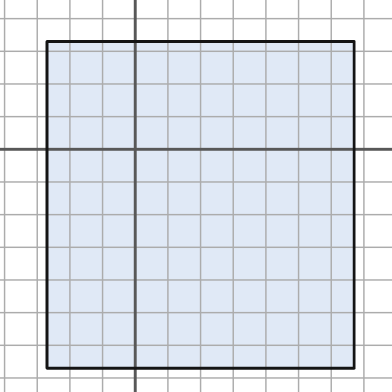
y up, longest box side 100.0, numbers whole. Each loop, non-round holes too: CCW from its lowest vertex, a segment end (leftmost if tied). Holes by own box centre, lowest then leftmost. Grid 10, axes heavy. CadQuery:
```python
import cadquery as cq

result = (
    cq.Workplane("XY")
    .moveTo(-27.0, -67.0)
    .lineTo(67.0, -67.0)
    .lineTo(67.0, 33.0)
    .lineTo(-27.0, 33.0)
    .close()
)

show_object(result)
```